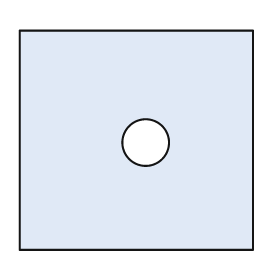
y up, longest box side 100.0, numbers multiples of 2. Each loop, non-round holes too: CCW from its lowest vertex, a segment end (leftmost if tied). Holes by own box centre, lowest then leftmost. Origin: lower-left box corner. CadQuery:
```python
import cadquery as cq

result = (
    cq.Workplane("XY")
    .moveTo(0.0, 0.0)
    .lineTo(100.0, 0.0)
    .lineTo(100.0, 94.0)
    .lineTo(0.0, 94.0)
    .close()
    .moveTo(54.0, 46.0)
    .circle(10.0)
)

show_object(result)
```